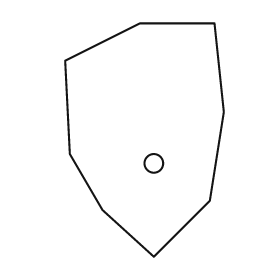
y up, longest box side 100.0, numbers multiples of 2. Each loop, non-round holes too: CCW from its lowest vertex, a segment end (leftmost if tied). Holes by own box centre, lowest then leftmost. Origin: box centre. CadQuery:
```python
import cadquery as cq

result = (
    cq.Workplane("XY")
    .moveTo(4.0, -50.0)
    .lineTo(28.0, -26.0)
    .lineTo(34.0, 12.0)
    .lineTo(30.0, 50.0)
    .lineTo(-2.0, 50.0)
    .lineTo(-34.0, 34.0)
    .lineTo(-32.0, -6.0)
    .lineTo(-18.0, -30.0)
    .close()
    .moveTo(4.0, -10.0)
    .circle(4.0)
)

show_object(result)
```